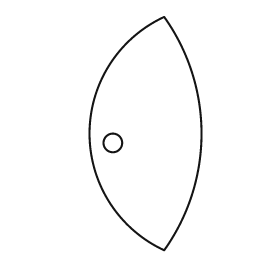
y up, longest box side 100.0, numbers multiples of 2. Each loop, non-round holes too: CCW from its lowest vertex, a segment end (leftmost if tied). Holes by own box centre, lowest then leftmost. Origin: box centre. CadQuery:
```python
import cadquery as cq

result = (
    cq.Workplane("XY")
    .moveTo(8.0, -50.0)
    .threePointArc((24.0, 0.0), (8.0, 50.0))
    .threePointArc((-24.0, 0.0), (8.0, -50.0))
    .close()
    .moveTo(-14.0, -4.0)
    .circle(4.0)
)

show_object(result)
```